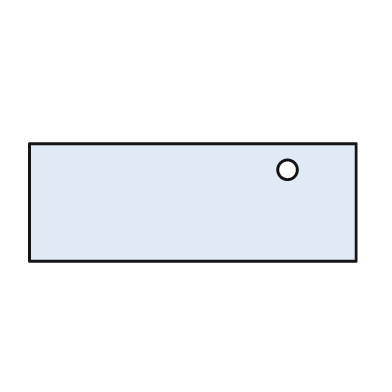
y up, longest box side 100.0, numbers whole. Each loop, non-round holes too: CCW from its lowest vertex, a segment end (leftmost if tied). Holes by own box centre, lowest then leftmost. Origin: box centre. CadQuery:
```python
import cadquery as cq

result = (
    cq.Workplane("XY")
    .moveTo(-50.0, -18.0)
    .lineTo(50.0, -18.0)
    .lineTo(50.0, 18.0)
    .lineTo(-50.0, 18.0)
    .close()
    .moveTo(29.0, 10.0)
    .circle(3.0)
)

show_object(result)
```